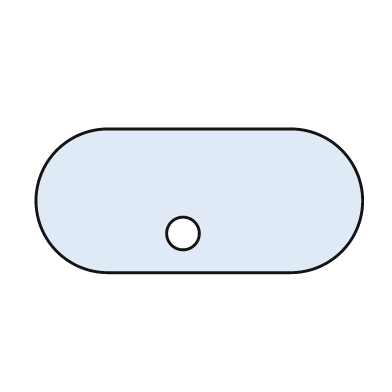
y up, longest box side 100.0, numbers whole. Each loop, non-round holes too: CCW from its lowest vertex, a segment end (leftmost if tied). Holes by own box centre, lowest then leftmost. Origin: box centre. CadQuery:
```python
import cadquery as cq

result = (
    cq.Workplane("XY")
    .moveTo(-28.0, -22.0)
    .lineTo(28.0, -22.0)
    .threePointArc((50.0, 0.0), (28.0, 22.0))
    .lineTo(-28.0, 22.0)
    .threePointArc((-50.0, 0.0), (-28.0, -22.0))
    .close()
    .moveTo(-5.0, -10.0)
    .circle(5.0)
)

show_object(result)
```